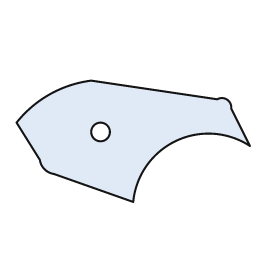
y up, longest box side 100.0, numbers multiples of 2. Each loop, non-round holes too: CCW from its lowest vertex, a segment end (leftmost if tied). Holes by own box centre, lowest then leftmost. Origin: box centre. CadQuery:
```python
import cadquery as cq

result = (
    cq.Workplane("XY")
    .moveTo(0.0, -26.0)
    .threePointArc((18.0, 0.0), (50.0, -2.0))
    .lineTo(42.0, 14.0)
    .threePointArc((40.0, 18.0), (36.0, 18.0))
    .lineTo(-18.0, 26.0)
    .threePointArc((-36.0, 20.0), (-50.0, 8.0))
    .lineTo(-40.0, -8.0)
    .threePointArc((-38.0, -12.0), (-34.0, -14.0))
    .close()
    .moveTo(-14.0, 4.0)
    .circle(4.0)
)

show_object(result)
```